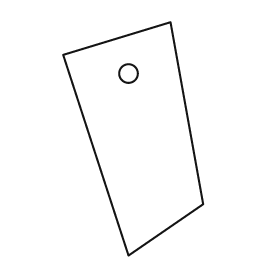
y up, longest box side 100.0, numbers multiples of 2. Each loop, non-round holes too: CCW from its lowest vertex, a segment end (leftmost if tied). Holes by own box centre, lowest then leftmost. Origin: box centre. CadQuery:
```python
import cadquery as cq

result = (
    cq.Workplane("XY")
    .moveTo(-2.0, -50.0)
    .lineTo(30.0, -28.0)
    .lineTo(16.0, 50.0)
    .lineTo(-30.0, 36.0)
    .close()
    .moveTo(-2.0, 28.0)
    .circle(4.0)
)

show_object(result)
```